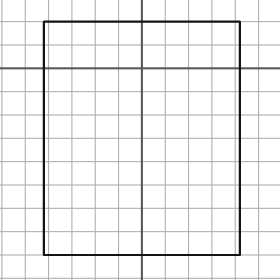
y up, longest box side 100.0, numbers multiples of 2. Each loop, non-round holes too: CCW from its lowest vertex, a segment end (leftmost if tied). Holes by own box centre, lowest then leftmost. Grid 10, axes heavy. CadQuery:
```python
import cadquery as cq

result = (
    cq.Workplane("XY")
    .moveTo(-42.0, -80.0)
    .lineTo(42.0, -80.0)
    .lineTo(42.0, 20.0)
    .lineTo(-42.0, 20.0)
    .close()
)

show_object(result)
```